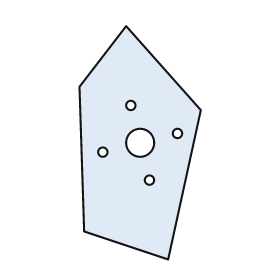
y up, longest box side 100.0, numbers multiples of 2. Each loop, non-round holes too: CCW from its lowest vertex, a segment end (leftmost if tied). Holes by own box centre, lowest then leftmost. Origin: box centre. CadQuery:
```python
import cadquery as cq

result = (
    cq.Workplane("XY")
    .moveTo(12.0, -50.0)
    .lineTo(26.0, 14.0)
    .lineTo(-6.0, 50.0)
    .lineTo(-26.0, 24.0)
    .lineTo(-24.0, -38.0)
    .close()
    .moveTo(4.0, -16.0)
    .circle(2.0)
    .moveTo(-16.0, -4.0)
    .circle(2.0)
    .moveTo(0.0, 0.0)
    .circle(6.0)
    .moveTo(16.0, 4.0)
    .circle(2.0)
    .moveTo(-4.0, 16.0)
    .circle(2.0)
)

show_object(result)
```